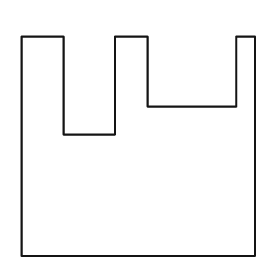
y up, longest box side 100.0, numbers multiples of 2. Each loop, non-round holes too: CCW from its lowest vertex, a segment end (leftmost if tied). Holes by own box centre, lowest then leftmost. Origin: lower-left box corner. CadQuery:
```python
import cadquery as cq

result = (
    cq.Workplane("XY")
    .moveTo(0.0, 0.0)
    .lineTo(100.0, 0.0)
    .lineTo(100.0, 94.0)
    .lineTo(92.0, 94.0)
    .lineTo(92.0, 64.0)
    .lineTo(54.0, 64.0)
    .lineTo(54.0, 94.0)
    .lineTo(40.0, 94.0)
    .lineTo(40.0, 52.0)
    .lineTo(18.0, 52.0)
    .lineTo(18.0, 94.0)
    .lineTo(0.0, 94.0)
    .close()
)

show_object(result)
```